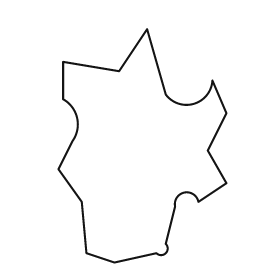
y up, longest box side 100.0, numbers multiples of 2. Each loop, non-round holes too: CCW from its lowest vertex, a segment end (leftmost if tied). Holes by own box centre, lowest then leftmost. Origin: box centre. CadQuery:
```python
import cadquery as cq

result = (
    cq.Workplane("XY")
    .moveTo(-12.0, -50.0)
    .lineTo(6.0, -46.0)
    .threePointArc((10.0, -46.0), (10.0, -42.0))
    .lineTo(14.0, -26.0)
    .threePointArc((18.0, -20.0), (24.0, -24.0))
    .lineTo(36.0, -16.0)
    .lineTo(28.0, -2.0)
    .lineTo(36.0, 14.0)
    .lineTo(30.0, 28.0)
    .threePointArc((22.0, 18.0), (10.0, 22.0))
    .lineTo(2.0, 50.0)
    .lineTo(-10.0, 32.0)
    .lineTo(-34.0, 36.0)
    .lineTo(-34.0, 20.0)
    .threePointArc((-28.0, 12.0), (-30.0, 2.0))
    .lineTo(-36.0, -10.0)
    .lineTo(-26.0, -24.0)
    .lineTo(-24.0, -46.0)
    .close()
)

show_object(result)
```